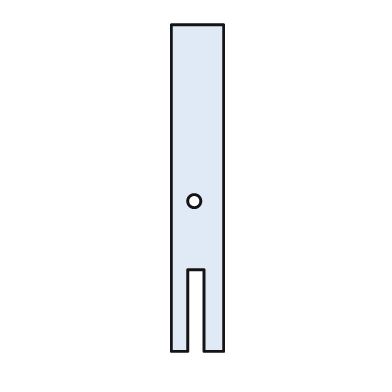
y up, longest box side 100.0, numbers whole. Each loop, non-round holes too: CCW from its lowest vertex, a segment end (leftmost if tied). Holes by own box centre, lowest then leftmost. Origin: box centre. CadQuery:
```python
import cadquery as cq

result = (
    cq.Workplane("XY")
    .moveTo(-8.0, -50.0)
    .lineTo(-3.0, -50.0)
    .lineTo(-3.0, -25.0)
    .lineTo(2.0, -25.0)
    .lineTo(2.0, -50.0)
    .lineTo(8.0, -50.0)
    .lineTo(8.0, 50.0)
    .lineTo(-8.0, 50.0)
    .close()
    .moveTo(-1.0, -4.0)
    .circle(2.0)
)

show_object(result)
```